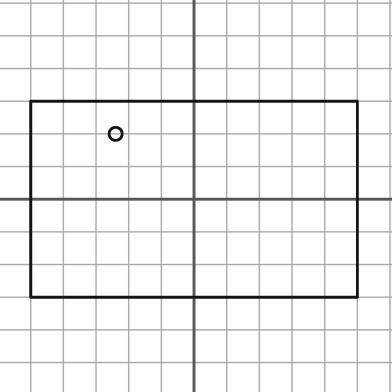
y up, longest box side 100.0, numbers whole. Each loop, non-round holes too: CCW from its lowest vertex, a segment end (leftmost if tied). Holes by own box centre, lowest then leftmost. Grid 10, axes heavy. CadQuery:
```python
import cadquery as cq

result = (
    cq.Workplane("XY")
    .moveTo(-50.0, -30.0)
    .lineTo(50.0, -30.0)
    .lineTo(50.0, 30.0)
    .lineTo(-50.0, 30.0)
    .close()
    .moveTo(-24.0, 20.0)
    .circle(2.0)
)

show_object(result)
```